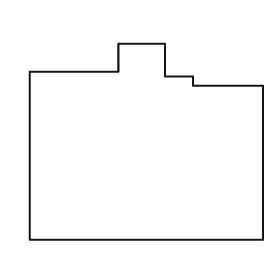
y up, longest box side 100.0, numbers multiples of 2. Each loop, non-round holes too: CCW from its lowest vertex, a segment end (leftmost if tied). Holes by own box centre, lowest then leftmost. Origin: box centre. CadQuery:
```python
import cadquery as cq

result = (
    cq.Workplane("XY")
    .moveTo(-50.0, -42.0)
    .lineTo(50.0, -42.0)
    .lineTo(50.0, 24.0)
    .lineTo(20.0, 24.0)
    .lineTo(20.0, 28.0)
    .lineTo(8.0, 28.0)
    .lineTo(8.0, 42.0)
    .lineTo(-12.0, 42.0)
    .lineTo(-12.0, 30.0)
    .lineTo(-50.0, 30.0)
    .close()
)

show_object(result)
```